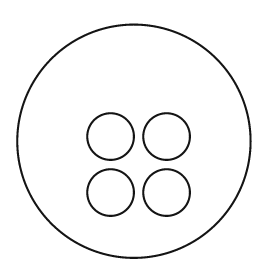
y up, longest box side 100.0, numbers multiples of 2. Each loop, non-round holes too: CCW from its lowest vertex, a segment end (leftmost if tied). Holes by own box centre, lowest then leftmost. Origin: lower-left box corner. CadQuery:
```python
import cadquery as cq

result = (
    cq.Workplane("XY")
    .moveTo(50.0, 50.0)
    .circle(50.0)
    .moveTo(40.0, 28.0)
    .circle(10.0)
    .moveTo(64.0, 28.0)
    .circle(10.0)
    .moveTo(40.0, 52.0)
    .circle(10.0)
    .moveTo(64.0, 52.0)
    .circle(10.0)
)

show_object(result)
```